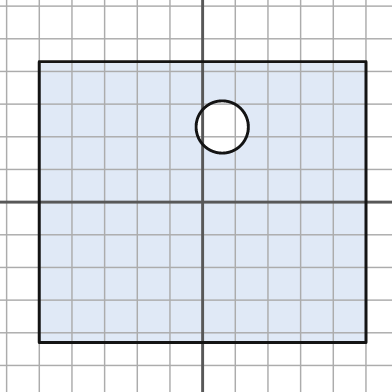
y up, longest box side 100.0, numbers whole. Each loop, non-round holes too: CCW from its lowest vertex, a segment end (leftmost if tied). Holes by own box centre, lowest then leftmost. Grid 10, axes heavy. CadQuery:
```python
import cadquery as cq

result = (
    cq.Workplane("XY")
    .moveTo(-50.0, -43.0)
    .lineTo(50.0, -43.0)
    .lineTo(50.0, 43.0)
    .lineTo(-50.0, 43.0)
    .close()
    .moveTo(6.0, 23.0)
    .circle(8.0)
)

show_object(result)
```